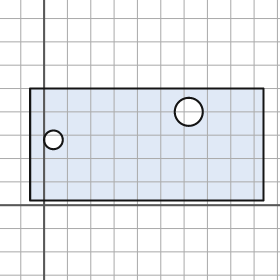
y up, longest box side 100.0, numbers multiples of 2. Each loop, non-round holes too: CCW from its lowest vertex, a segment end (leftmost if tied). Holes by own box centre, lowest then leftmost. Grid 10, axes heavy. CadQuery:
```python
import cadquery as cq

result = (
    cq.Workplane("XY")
    .moveTo(-6.0, 2.0)
    .lineTo(94.0, 2.0)
    .lineTo(94.0, 50.0)
    .lineTo(-6.0, 50.0)
    .close()
    .moveTo(4.0, 28.0)
    .circle(4.0)
    .moveTo(62.0, 40.0)
    .circle(6.0)
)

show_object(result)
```